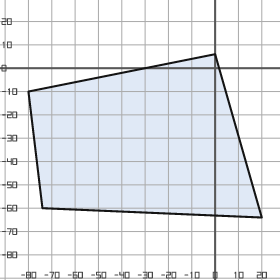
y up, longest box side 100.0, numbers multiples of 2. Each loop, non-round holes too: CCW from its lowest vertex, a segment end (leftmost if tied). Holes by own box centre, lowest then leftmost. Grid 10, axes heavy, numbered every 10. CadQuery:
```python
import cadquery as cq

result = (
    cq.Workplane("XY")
    .moveTo(20.0, -64.0)
    .lineTo(0.0, 6.0)
    .lineTo(-80.0, -10.0)
    .lineTo(-74.0, -60.0)
    .close()
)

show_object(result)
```